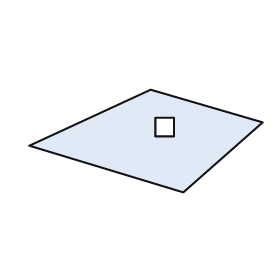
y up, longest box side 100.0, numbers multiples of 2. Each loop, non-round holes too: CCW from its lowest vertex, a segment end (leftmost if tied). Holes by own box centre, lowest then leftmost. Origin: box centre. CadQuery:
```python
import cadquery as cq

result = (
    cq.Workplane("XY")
    .moveTo(16.0, -22.0)
    .lineTo(50.0, 8.0)
    .lineTo(2.0, 22.0)
    .lineTo(-50.0, -2.0)
    .close()
    .moveTo(4.0, 2.0)
    .lineTo(12.0, 2.0)
    .lineTo(12.0, 10.0)
    .lineTo(4.0, 10.0)
    .close()
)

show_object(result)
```